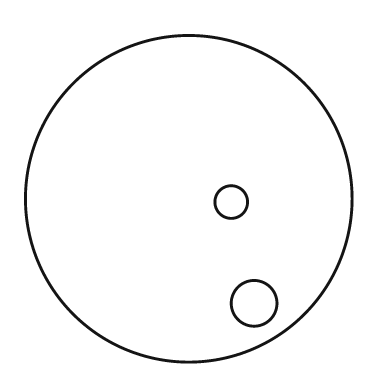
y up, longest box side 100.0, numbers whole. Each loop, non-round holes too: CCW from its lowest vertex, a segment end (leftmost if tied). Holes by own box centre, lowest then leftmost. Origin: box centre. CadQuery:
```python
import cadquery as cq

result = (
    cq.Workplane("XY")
    .moveTo(0.0, 0.0)
    .circle(50.0)
    .moveTo(20.0, -32.0)
    .circle(7.0)
    .moveTo(13.0, -1.0)
    .circle(5.0)
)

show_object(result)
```